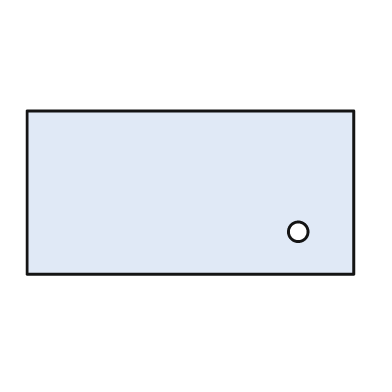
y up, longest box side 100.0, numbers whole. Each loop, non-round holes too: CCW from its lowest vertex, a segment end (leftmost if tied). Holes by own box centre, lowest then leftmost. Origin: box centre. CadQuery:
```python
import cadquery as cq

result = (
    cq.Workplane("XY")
    .moveTo(-50.0, -25.0)
    .lineTo(50.0, -25.0)
    .lineTo(50.0, 25.0)
    .lineTo(-50.0, 25.0)
    .close()
    .moveTo(33.0, -12.0)
    .circle(3.0)
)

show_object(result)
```